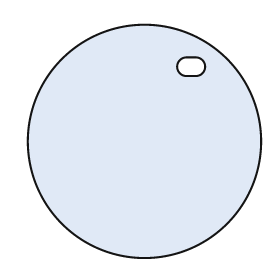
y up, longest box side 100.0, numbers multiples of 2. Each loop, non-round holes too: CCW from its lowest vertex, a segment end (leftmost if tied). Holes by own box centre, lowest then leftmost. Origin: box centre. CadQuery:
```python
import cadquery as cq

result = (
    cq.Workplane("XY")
    .moveTo(0.0, 0.0)
    .circle(50.0)
    .moveTo(18.0, 28.0)
    .lineTo(22.0, 28.0)
    .threePointArc((26.0, 32.0), (22.0, 36.0))
    .lineTo(18.0, 36.0)
    .threePointArc((14.0, 32.0), (18.0, 28.0))
    .close()
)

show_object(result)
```